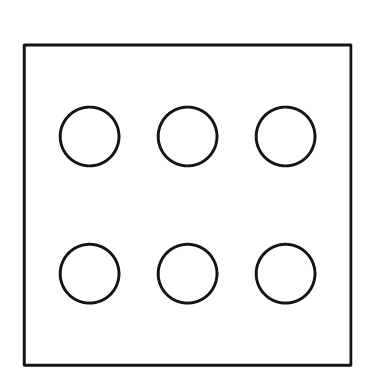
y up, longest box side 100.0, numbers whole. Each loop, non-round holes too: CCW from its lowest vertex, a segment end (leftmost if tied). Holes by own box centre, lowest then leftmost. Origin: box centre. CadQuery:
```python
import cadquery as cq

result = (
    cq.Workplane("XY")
    .moveTo(-50.0, -49.0)
    .lineTo(50.0, -49.0)
    .lineTo(50.0, 49.0)
    .lineTo(-50.0, 49.0)
    .close()
    .moveTo(-30.0, -21.0)
    .circle(9.0)
    .moveTo(0.0, -21.0)
    .circle(9.0)
    .moveTo(30.0, -21.0)
    .circle(9.0)
    .moveTo(-30.0, 21.0)
    .circle(9.0)
    .moveTo(0.0, 21.0)
    .circle(9.0)
    .moveTo(30.0, 21.0)
    .circle(9.0)
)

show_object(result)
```